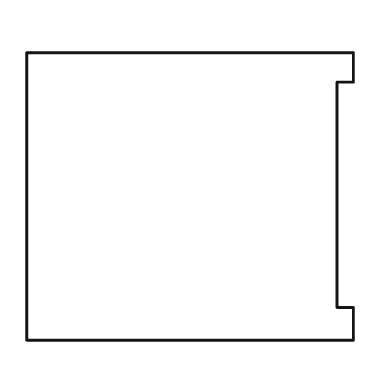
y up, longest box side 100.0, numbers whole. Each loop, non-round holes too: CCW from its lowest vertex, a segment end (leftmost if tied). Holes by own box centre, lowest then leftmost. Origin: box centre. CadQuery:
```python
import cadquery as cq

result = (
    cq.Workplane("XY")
    .moveTo(-50.0, -44.0)
    .lineTo(50.0, -44.0)
    .lineTo(50.0, -34.0)
    .lineTo(45.0, -34.0)
    .lineTo(45.0, 35.0)
    .lineTo(50.0, 35.0)
    .lineTo(50.0, 44.0)
    .lineTo(-50.0, 44.0)
    .close()
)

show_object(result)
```